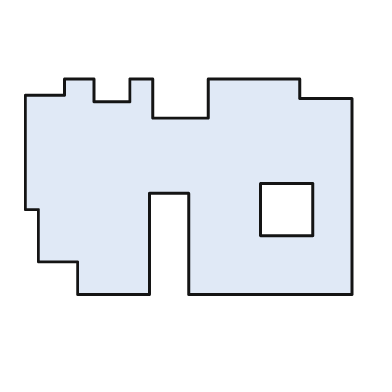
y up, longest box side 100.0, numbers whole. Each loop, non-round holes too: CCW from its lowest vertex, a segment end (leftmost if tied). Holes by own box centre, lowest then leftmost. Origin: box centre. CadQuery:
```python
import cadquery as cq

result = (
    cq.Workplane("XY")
    .moveTo(-34.0, -33.0)
    .lineTo(-12.0, -33.0)
    .lineTo(-12.0, -2.0)
    .lineTo(0.0, -2.0)
    .lineTo(0.0, -33.0)
    .lineTo(50.0, -33.0)
    .lineTo(50.0, 27.0)
    .lineTo(34.0, 27.0)
    .lineTo(34.0, 33.0)
    .lineTo(6.0, 33.0)
    .lineTo(6.0, 21.0)
    .lineTo(-11.0, 21.0)
    .lineTo(-11.0, 33.0)
    .lineTo(-18.0, 33.0)
    .lineTo(-18.0, 26.0)
    .lineTo(-29.0, 26.0)
    .lineTo(-29.0, 33.0)
    .lineTo(-38.0, 33.0)
    .lineTo(-38.0, 28.0)
    .lineTo(-50.0, 28.0)
    .lineTo(-50.0, -7.0)
    .lineTo(-46.0, -7.0)
    .lineTo(-46.0, -23.0)
    .lineTo(-34.0, -23.0)
    .close()
    .moveTo(22.0, -15.0)
    .lineTo(38.0, -15.0)
    .lineTo(38.0, 1.0)
    .lineTo(22.0, 1.0)
    .close()
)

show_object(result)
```